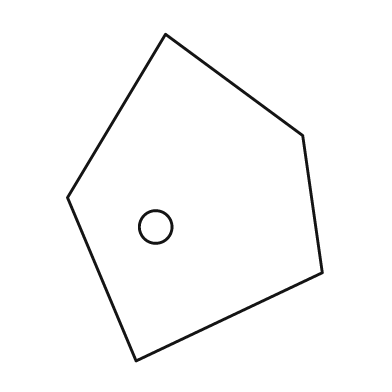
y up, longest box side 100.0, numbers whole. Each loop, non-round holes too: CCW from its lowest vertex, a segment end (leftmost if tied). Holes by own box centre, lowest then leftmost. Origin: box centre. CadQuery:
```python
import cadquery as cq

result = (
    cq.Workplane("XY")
    .moveTo(-18.0, -50.0)
    .lineTo(39.0, -23.0)
    .lineTo(33.0, 19.0)
    .lineTo(-9.0, 50.0)
    .lineTo(-39.0, 0.0)
    .close()
    .moveTo(-12.0, -9.0)
    .circle(5.0)
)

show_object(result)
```